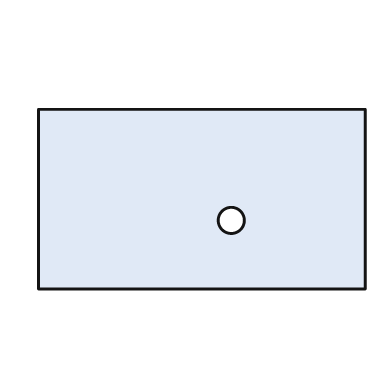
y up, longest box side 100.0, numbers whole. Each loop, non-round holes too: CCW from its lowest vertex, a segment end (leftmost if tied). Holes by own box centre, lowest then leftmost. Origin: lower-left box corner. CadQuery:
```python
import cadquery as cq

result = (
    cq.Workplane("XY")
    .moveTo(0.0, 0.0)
    .lineTo(100.0, 0.0)
    .lineTo(100.0, 55.0)
    .lineTo(0.0, 55.0)
    .close()
    .moveTo(59.0, 21.0)
    .circle(4.0)
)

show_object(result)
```